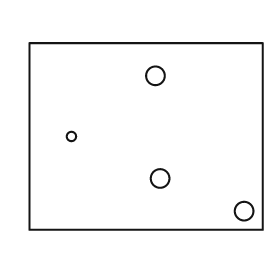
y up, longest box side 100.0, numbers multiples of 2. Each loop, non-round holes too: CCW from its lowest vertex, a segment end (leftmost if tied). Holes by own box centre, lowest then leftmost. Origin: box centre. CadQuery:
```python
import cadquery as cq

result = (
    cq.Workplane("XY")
    .moveTo(-50.0, -40.0)
    .lineTo(50.0, -40.0)
    .lineTo(50.0, 40.0)
    .lineTo(-50.0, 40.0)
    .close()
    .moveTo(42.0, -32.0)
    .circle(4.0)
    .moveTo(6.0, -18.0)
    .circle(4.0)
    .moveTo(-32.0, 0.0)
    .circle(2.0)
    .moveTo(4.0, 26.0)
    .circle(4.0)
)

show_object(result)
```